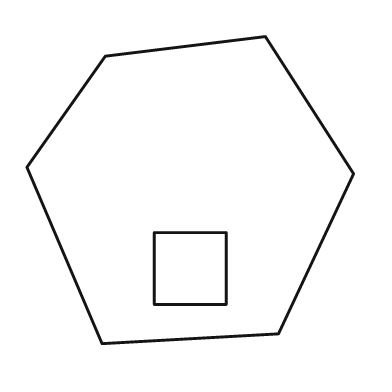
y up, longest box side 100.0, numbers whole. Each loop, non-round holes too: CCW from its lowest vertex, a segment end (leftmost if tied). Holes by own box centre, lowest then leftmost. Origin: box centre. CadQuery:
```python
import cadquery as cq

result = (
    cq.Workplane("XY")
    .moveTo(-27.0, -47.0)
    .lineTo(27.0, -44.0)
    .lineTo(50.0, 5.0)
    .lineTo(23.0, 47.0)
    .lineTo(-26.0, 41.0)
    .lineTo(-50.0, 7.0)
    .close()
    .moveTo(-11.0, -35.0)
    .lineTo(11.0, -35.0)
    .lineTo(11.0, -13.0)
    .lineTo(-11.0, -13.0)
    .close()
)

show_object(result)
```